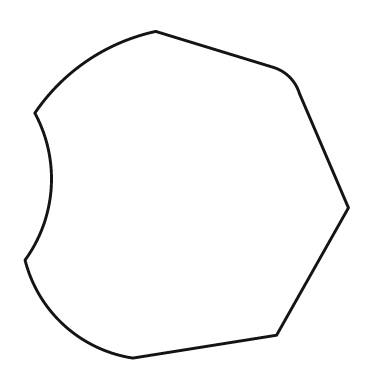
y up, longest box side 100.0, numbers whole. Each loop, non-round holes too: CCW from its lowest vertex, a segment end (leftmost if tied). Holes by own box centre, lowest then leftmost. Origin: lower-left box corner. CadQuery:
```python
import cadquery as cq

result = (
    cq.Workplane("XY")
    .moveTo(33.0, 0.0)
    .lineTo(77.0, 7.0)
    .lineTo(99.0, 46.0)
    .lineTo(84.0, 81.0)
    .threePointArc((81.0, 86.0), (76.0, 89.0))
    .lineTo(40.0, 100.0)
    .threePointArc((19.0, 91.0), (3.0, 75.0))
    .threePointArc((8.0, 52.0), (0.0, 30.0))
    .threePointArc((12.0, 10.0), (33.0, 0.0))
    .close()
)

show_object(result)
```